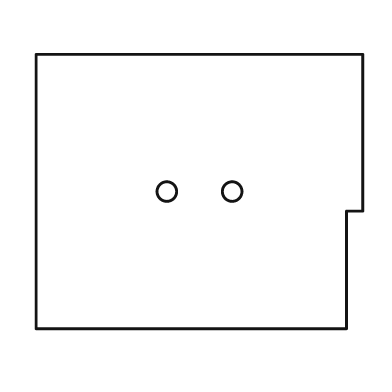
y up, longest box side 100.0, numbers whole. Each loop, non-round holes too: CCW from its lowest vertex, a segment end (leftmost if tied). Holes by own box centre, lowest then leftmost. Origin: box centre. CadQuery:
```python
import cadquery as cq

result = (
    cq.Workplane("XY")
    .moveTo(-50.0, -42.0)
    .lineTo(45.0, -42.0)
    .lineTo(45.0, -6.0)
    .lineTo(50.0, -6.0)
    .lineTo(50.0, 42.0)
    .lineTo(-50.0, 42.0)
    .close()
    .moveTo(-10.0, 0.0)
    .circle(3.0)
    .moveTo(10.0, 0.0)
    .circle(3.0)
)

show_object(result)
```